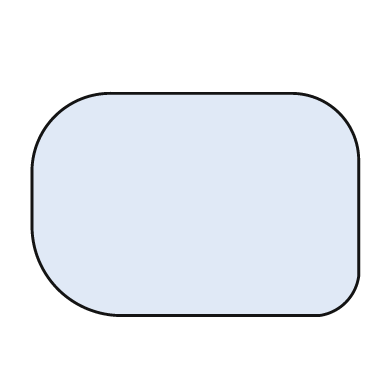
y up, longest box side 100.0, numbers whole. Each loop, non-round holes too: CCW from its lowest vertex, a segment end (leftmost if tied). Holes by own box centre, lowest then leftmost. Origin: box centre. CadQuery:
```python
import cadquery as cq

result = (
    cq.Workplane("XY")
    .moveTo(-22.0, -34.0)
    .lineTo(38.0, -34.0)
    .threePointArc((46.0, -30.0), (50.0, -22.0))
    .lineTo(50.0, 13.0)
    .threePointArc((44.0, 28.0), (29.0, 34.0))
    .lineTo(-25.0, 34.0)
    .threePointArc((-43.0, 27.0), (-50.0, 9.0))
    .lineTo(-50.0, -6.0)
    .threePointArc((-42.0, -26.0), (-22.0, -34.0))
    .close()
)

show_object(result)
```